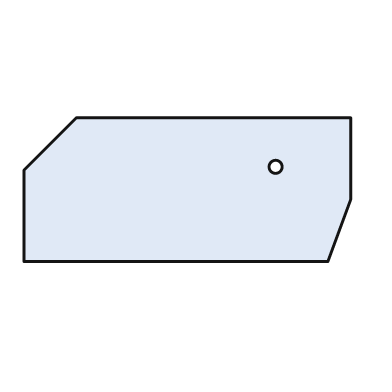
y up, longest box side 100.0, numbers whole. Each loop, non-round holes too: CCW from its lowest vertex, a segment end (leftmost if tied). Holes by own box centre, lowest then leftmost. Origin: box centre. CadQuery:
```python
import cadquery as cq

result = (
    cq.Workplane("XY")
    .moveTo(-50.0, -22.0)
    .lineTo(43.0, -22.0)
    .lineTo(50.0, -3.0)
    .lineTo(50.0, 22.0)
    .lineTo(-34.0, 22.0)
    .lineTo(-50.0, 6.0)
    .close()
    .moveTo(27.0, 7.0)
    .circle(2.0)
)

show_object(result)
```